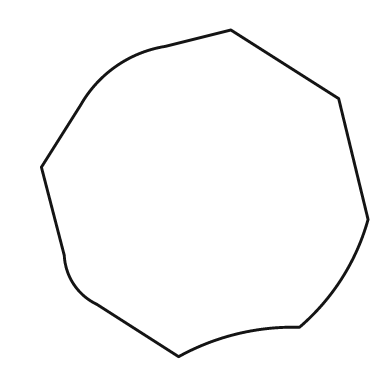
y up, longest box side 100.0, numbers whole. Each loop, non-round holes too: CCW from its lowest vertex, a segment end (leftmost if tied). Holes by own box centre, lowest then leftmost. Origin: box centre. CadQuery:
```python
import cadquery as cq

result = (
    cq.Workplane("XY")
    .moveTo(-8.0, -50.0)
    .threePointArc((10.0, -43.0), (29.0, -41.0))
    .threePointArc((42.0, -26.0), (50.0, -8.0))
    .lineTo(41.0, 29.0)
    .lineTo(8.0, 50.0)
    .lineTo(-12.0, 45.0)
    .threePointArc((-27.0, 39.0), (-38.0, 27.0))
    .lineTo(-50.0, 8.0)
    .lineTo(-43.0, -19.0)
    .threePointArc((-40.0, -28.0), (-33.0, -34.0))
    .close()
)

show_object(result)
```